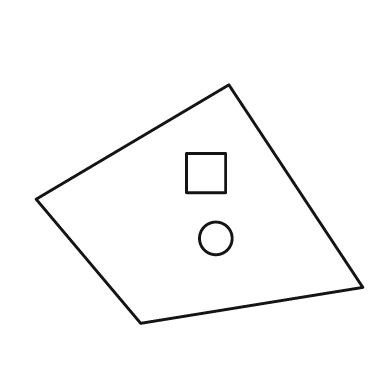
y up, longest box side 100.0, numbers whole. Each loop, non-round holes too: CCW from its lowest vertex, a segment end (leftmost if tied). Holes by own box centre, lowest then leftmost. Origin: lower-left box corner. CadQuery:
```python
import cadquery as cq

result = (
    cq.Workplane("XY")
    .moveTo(32.0, 0.0)
    .lineTo(100.0, 11.0)
    .lineTo(59.0, 73.0)
    .lineTo(0.0, 38.0)
    .close()
    .moveTo(55.0, 26.0)
    .circle(5.0)
    .moveTo(46.0, 40.0)
    .lineTo(58.0, 40.0)
    .lineTo(58.0, 52.0)
    .lineTo(46.0, 52.0)
    .close()
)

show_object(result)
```